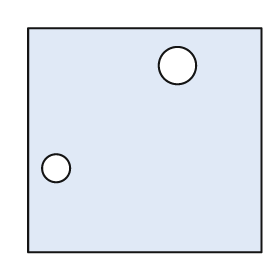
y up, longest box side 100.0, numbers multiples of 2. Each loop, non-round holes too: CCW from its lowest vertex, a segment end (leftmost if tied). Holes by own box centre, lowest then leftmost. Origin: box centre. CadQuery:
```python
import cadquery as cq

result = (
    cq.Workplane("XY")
    .moveTo(-50.0, -48.0)
    .lineTo(50.0, -48.0)
    .lineTo(50.0, 48.0)
    .lineTo(-50.0, 48.0)
    .close()
    .moveTo(-38.0, -12.0)
    .circle(6.0)
    .moveTo(14.0, 32.0)
    .circle(8.0)
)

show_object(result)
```